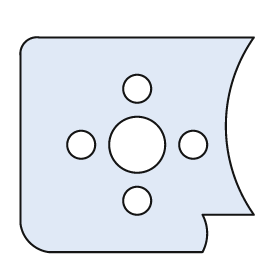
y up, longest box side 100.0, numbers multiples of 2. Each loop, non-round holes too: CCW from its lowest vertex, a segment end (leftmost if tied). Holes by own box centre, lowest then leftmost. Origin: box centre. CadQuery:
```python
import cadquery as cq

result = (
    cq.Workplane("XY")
    .moveTo(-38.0, -46.0)
    .lineTo(28.0, -46.0)
    .threePointArc((30.0, -38.0), (28.0, -30.0))
    .lineTo(50.0, -30.0)
    .threePointArc((38.0, 8.0), (50.0, 46.0))
    .lineTo(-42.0, 46.0)
    .threePointArc((-48.0, 44.0), (-50.0, 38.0))
    .lineTo(-50.0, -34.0)
    .threePointArc((-46.0, -42.0), (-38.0, -46.0))
    .close()
    .moveTo(0.0, -24.0)
    .circle(6.0)
    .moveTo(-24.0, 0.0)
    .circle(6.0)
    .moveTo(0.0, 0.0)
    .circle(12.0)
    .moveTo(24.0, 0.0)
    .circle(6.0)
    .moveTo(0.0, 24.0)
    .circle(6.0)
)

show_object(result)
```